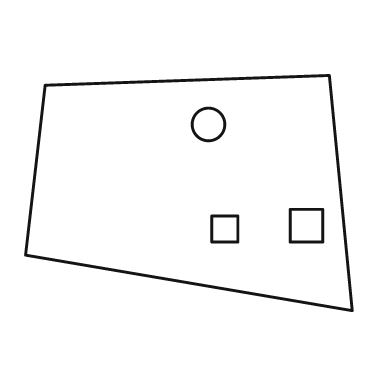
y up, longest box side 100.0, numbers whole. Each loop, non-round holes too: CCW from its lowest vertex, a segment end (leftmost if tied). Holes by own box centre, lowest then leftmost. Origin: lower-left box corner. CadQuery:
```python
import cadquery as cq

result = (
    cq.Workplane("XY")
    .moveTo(100.0, 0.0)
    .lineTo(93.0, 72.0)
    .lineTo(6.0, 69.0)
    .lineTo(0.0, 17.0)
    .close()
    .moveTo(57.0, 21.0)
    .lineTo(65.0, 21.0)
    .lineTo(65.0, 29.0)
    .lineTo(57.0, 29.0)
    .close()
    .moveTo(81.0, 21.0)
    .lineTo(91.0, 21.0)
    .lineTo(91.0, 31.0)
    .lineTo(81.0, 31.0)
    .close()
    .moveTo(56.0, 57.0)
    .circle(5.0)
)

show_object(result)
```